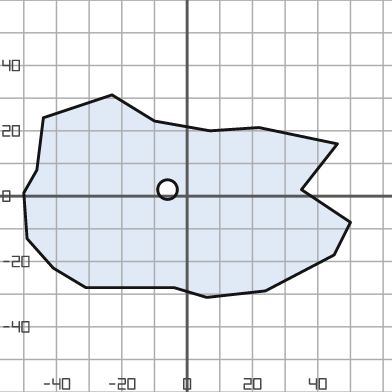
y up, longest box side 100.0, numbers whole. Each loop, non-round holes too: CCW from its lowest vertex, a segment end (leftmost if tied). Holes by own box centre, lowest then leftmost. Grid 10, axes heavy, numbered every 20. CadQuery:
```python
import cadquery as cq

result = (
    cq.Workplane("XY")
    .moveTo(6.0, -31.0)
    .lineTo(24.0, -29.0)
    .lineTo(45.0, -18.0)
    .lineTo(50.0, -8.0)
    .lineTo(35.0, 2.0)
    .lineTo(46.0, 16.0)
    .lineTo(22.0, 21.0)
    .lineTo(7.0, 20.0)
    .lineTo(-10.0, 23.0)
    .lineTo(-23.0, 31.0)
    .lineTo(-44.0, 24.0)
    .lineTo(-46.0, 8.0)
    .lineTo(-50.0, 1.0)
    .lineTo(-49.0, -13.0)
    .lineTo(-41.0, -22.0)
    .lineTo(-31.0, -28.0)
    .lineTo(-4.0, -28.0)
    .close()
    .moveTo(-6.0, 2.0)
    .circle(3.0)
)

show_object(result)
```